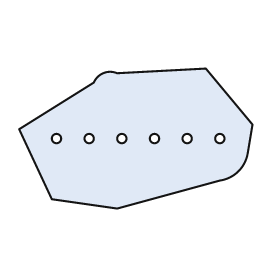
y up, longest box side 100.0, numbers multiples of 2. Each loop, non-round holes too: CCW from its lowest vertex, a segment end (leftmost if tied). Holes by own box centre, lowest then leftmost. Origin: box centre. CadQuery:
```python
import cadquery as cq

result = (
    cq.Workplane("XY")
    .moveTo(-8.0, -30.0)
    .lineTo(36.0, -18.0)
    .threePointArc((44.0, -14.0), (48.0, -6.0))
    .lineTo(50.0, 6.0)
    .lineTo(30.0, 30.0)
    .lineTo(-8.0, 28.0)
    .threePointArc((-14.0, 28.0), (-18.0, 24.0))
    .lineTo(-50.0, 4.0)
    .lineTo(-36.0, -26.0)
    .close()
    .moveTo(-34.0, 0.0)
    .circle(2.0)
    .moveTo(-20.0, 0.0)
    .circle(2.0)
    .moveTo(-6.0, 0.0)
    .circle(2.0)
    .moveTo(8.0, 0.0)
    .circle(2.0)
    .moveTo(22.0, 0.0)
    .circle(2.0)
    .moveTo(36.0, 0.0)
    .circle(2.0)
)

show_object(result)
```